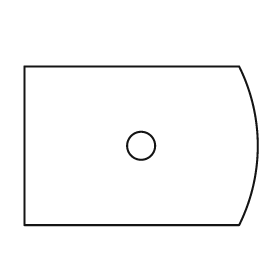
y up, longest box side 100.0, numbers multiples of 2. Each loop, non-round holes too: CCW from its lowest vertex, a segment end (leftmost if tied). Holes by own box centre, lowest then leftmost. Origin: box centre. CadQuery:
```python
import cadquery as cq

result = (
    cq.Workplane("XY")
    .moveTo(-50.0, -34.0)
    .lineTo(42.0, -34.0)
    .threePointArc((50.0, 0.0), (42.0, 34.0))
    .lineTo(-50.0, 34.0)
    .close()
    .moveTo(0.0, 0.0)
    .circle(6.0)
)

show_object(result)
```